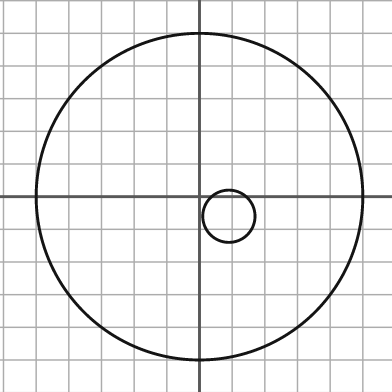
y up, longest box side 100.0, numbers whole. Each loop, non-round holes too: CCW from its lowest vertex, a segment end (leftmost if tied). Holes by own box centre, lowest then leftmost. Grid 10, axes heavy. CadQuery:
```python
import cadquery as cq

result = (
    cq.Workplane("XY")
    .moveTo(0.0, 0.0)
    .circle(50.0)
    .moveTo(9.0, -6.0)
    .circle(8.0)
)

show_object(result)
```